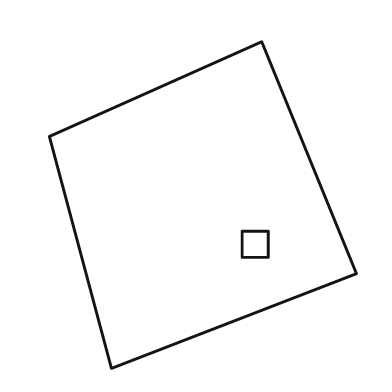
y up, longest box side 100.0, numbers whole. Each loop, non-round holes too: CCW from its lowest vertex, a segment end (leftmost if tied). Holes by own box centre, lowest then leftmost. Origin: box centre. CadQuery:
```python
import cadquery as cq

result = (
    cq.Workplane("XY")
    .moveTo(-28.0, -50.0)
    .lineTo(47.0, -21.0)
    .lineTo(18.0, 50.0)
    .lineTo(-47.0, 21.0)
    .close()
    .moveTo(12.0, -16.0)
    .lineTo(20.0, -16.0)
    .lineTo(20.0, -8.0)
    .lineTo(12.0, -8.0)
    .close()
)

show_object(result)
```